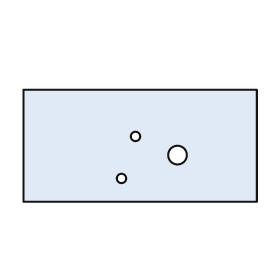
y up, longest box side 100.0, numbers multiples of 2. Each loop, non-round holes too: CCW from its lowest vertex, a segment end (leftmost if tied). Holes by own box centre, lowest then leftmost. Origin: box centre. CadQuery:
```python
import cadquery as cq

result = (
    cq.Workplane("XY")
    .moveTo(-50.0, -24.0)
    .lineTo(50.0, -24.0)
    .lineTo(50.0, 24.0)
    .lineTo(-50.0, 24.0)
    .close()
    .moveTo(-8.0, -14.0)
    .circle(2.0)
    .moveTo(16.0, -4.0)
    .circle(4.0)
    .moveTo(-2.0, 4.0)
    .circle(2.0)
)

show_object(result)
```